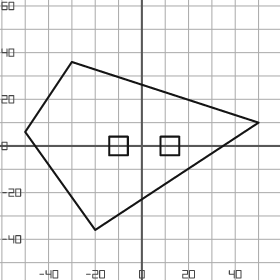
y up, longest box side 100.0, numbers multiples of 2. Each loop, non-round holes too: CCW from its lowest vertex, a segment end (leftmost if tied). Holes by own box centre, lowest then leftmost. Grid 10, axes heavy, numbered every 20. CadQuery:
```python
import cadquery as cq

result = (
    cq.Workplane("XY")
    .moveTo(-20.0, -36.0)
    .lineTo(50.0, 10.0)
    .lineTo(-30.0, 36.0)
    .lineTo(-50.0, 6.0)
    .close()
    .moveTo(-14.0, -4.0)
    .lineTo(-6.0, -4.0)
    .lineTo(-6.0, 4.0)
    .lineTo(-14.0, 4.0)
    .close()
    .moveTo(8.0, -4.0)
    .lineTo(16.0, -4.0)
    .lineTo(16.0, 4.0)
    .lineTo(8.0, 4.0)
    .close()
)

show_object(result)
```